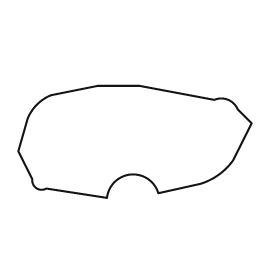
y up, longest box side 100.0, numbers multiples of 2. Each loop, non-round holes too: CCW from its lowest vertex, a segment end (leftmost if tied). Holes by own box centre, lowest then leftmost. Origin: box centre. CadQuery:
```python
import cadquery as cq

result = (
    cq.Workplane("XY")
    .moveTo(-12.0, -24.0)
    .threePointArc((-2.0, -14.0), (10.0, -22.0))
    .lineTo(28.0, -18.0)
    .threePointArc((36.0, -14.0), (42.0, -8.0))
    .lineTo(50.0, 8.0)
    .lineTo(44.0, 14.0)
    .threePointArc((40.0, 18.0), (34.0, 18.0))
    .lineTo(2.0, 24.0)
    .lineTo(-16.0, 24.0)
    .lineTo(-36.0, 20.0)
    .threePointArc((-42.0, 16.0), (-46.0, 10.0))
    .lineTo(-50.0, -4.0)
    .lineTo(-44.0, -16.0)
    .threePointArc((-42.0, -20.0), (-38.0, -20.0))
    .close()
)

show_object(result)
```